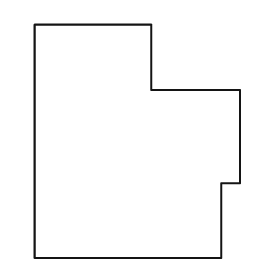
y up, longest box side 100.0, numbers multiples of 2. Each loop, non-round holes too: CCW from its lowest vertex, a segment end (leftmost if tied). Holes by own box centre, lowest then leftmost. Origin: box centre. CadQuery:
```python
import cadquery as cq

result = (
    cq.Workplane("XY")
    .moveTo(-44.0, -50.0)
    .lineTo(36.0, -50.0)
    .lineTo(36.0, -18.0)
    .lineTo(44.0, -18.0)
    .lineTo(44.0, 22.0)
    .lineTo(6.0, 22.0)
    .lineTo(6.0, 50.0)
    .lineTo(-44.0, 50.0)
    .close()
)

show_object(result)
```